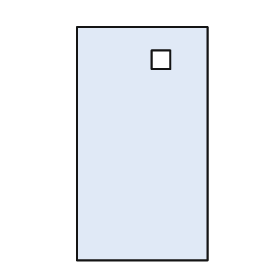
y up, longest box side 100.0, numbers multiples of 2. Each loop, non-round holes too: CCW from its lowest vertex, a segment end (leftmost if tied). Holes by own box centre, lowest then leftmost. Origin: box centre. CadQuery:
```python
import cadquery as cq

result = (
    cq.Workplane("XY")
    .moveTo(-28.0, -50.0)
    .lineTo(28.0, -50.0)
    .lineTo(28.0, 50.0)
    .lineTo(-28.0, 50.0)
    .close()
    .moveTo(4.0, 32.0)
    .lineTo(12.0, 32.0)
    .lineTo(12.0, 40.0)
    .lineTo(4.0, 40.0)
    .close()
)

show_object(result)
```